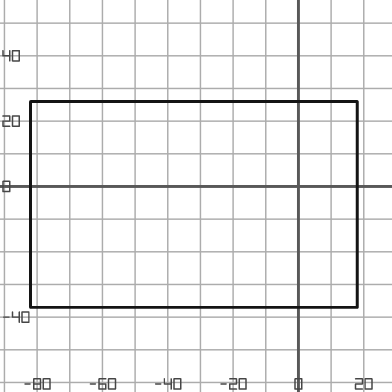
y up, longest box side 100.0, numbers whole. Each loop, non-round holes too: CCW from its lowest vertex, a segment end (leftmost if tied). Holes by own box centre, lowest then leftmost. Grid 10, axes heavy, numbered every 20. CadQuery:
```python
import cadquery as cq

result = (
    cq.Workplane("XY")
    .moveTo(-82.0, -37.0)
    .lineTo(18.0, -37.0)
    .lineTo(18.0, 26.0)
    .lineTo(-82.0, 26.0)
    .close()
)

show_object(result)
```